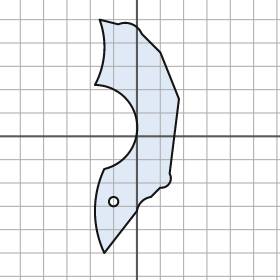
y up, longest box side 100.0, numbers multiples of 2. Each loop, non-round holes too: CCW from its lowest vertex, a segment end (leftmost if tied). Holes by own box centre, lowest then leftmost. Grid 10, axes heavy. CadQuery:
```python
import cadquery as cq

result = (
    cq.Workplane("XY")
    .moveTo(-14.0, -50.0)
    .lineTo(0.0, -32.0)
    .threePointArc((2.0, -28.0), (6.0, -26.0))
    .lineTo(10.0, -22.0)
    .threePointArc((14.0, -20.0), (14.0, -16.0))
    .lineTo(18.0, 16.0)
    .lineTo(10.0, 36.0)
    .lineTo(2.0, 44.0)
    .threePointArc((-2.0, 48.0), (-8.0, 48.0))
    .lineTo(-16.0, 50.0)
    .threePointArc((-14.0, 36.0), (-18.0, 22.0))
    .threePointArc((0.0, 6.0), (-14.0, -14.0))
    .threePointArc((-18.0, -32.0), (-14.0, -50.0))
    .close()
    .moveTo(-10.0, -28.0)
    .circle(2.0)
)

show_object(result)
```